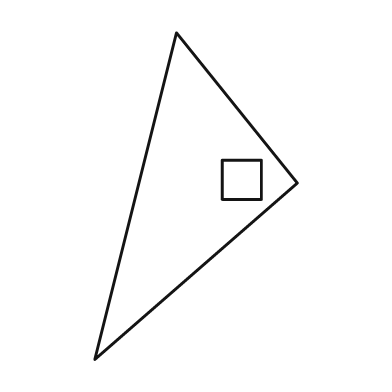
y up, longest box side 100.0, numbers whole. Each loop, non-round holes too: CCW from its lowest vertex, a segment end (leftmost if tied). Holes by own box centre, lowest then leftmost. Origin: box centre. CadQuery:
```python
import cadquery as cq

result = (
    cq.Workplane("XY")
    .moveTo(-31.0, -50.0)
    .lineTo(31.0, 4.0)
    .lineTo(-6.0, 50.0)
    .close()
    .moveTo(8.0, -1.0)
    .lineTo(20.0, -1.0)
    .lineTo(20.0, 11.0)
    .lineTo(8.0, 11.0)
    .close()
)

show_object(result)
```